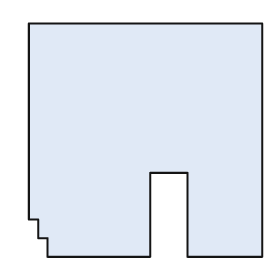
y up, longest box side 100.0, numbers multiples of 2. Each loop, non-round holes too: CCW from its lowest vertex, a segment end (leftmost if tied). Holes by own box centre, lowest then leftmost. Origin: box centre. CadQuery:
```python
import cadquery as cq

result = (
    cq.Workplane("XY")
    .moveTo(-42.0, -50.0)
    .lineTo(2.0, -50.0)
    .lineTo(2.0, -14.0)
    .lineTo(18.0, -14.0)
    .lineTo(18.0, -50.0)
    .lineTo(50.0, -50.0)
    .lineTo(50.0, 50.0)
    .lineTo(-50.0, 50.0)
    .lineTo(-50.0, -34.0)
    .lineTo(-46.0, -34.0)
    .lineTo(-46.0, -42.0)
    .lineTo(-42.0, -42.0)
    .close()
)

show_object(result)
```